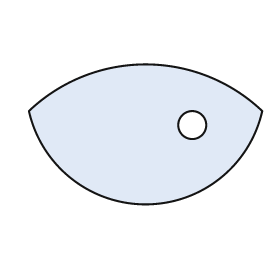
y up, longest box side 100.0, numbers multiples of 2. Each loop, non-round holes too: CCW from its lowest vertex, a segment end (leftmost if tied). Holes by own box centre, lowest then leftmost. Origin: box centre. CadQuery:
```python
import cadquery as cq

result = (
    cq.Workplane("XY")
    .moveTo(-50.0, 10.0)
    .threePointArc((0.0, -30.0), (50.0, 10.0))
    .threePointArc((0.0, 30.0), (-50.0, 10.0))
    .close()
    .moveTo(20.0, 4.0)
    .circle(6.0)
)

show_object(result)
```